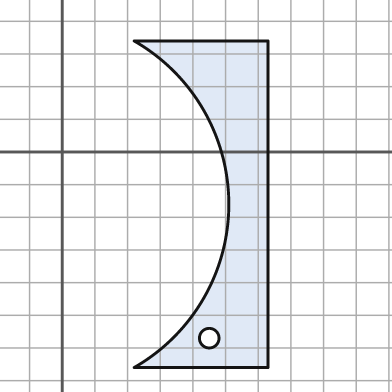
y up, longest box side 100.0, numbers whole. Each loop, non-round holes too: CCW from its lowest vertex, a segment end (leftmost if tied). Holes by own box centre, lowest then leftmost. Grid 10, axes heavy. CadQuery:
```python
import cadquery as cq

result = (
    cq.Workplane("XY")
    .moveTo(22.0, -66.0)
    .lineTo(63.0, -66.0)
    .lineTo(63.0, 34.0)
    .lineTo(22.0, 34.0)
    .threePointArc((51.0, -16.0), (22.0, -66.0))
    .close()
    .moveTo(45.0, -57.0)
    .circle(3.0)
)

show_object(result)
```